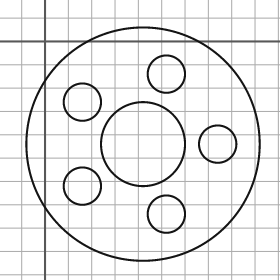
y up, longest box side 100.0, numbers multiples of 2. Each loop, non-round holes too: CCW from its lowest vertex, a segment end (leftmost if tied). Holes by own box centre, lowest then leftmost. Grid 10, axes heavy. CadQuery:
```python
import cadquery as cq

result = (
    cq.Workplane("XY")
    .moveTo(42.0, -44.0)
    .circle(50.0)
    .moveTo(52.0, -74.0)
    .circle(8.0)
    .moveTo(16.0, -62.0)
    .circle(8.0)
    .moveTo(42.0, -44.0)
    .circle(18.0)
    .moveTo(74.0, -44.0)
    .circle(8.0)
    .moveTo(16.0, -26.0)
    .circle(8.0)
    .moveTo(52.0, -14.0)
    .circle(8.0)
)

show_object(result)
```